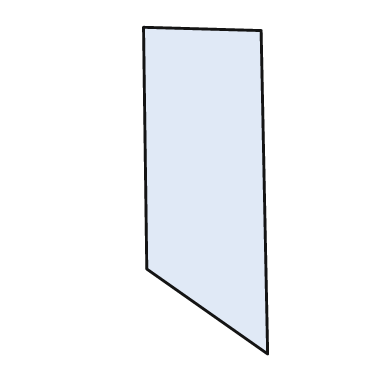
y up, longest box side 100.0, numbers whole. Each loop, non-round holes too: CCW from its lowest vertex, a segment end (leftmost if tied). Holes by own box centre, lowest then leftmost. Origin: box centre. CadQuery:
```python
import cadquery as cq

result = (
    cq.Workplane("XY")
    .moveTo(19.0, -50.0)
    .lineTo(17.0, 49.0)
    .lineTo(-19.0, 50.0)
    .lineTo(-18.0, -24.0)
    .close()
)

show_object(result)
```